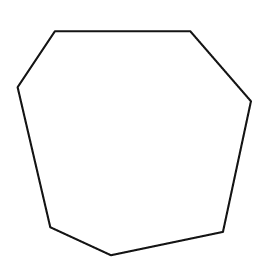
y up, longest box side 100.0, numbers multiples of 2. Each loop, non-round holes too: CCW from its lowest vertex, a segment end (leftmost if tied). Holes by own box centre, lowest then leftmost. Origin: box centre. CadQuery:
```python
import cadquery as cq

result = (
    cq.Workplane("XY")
    .moveTo(-10.0, -48.0)
    .lineTo(38.0, -38.0)
    .lineTo(50.0, 18.0)
    .lineTo(24.0, 48.0)
    .lineTo(-34.0, 48.0)
    .lineTo(-50.0, 24.0)
    .lineTo(-36.0, -36.0)
    .close()
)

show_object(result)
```